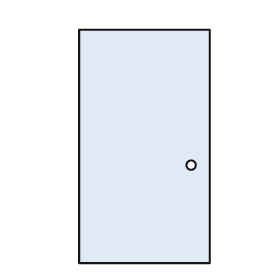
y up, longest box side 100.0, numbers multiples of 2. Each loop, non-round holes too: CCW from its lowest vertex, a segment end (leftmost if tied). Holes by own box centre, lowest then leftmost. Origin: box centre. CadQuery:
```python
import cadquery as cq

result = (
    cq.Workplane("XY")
    .moveTo(-28.0, -50.0)
    .lineTo(28.0, -50.0)
    .lineTo(28.0, 50.0)
    .lineTo(-28.0, 50.0)
    .close()
    .moveTo(20.0, -8.0)
    .circle(2.0)
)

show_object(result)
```